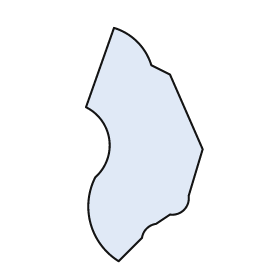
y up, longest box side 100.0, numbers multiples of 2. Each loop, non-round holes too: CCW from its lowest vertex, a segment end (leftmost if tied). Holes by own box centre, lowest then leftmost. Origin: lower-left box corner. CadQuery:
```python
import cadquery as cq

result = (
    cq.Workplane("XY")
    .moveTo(14.0, 0.0)
    .lineTo(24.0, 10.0)
    .threePointArc((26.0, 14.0), (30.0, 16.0))
    .lineTo(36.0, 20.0)
    .threePointArc((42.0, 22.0), (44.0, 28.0))
    .lineTo(50.0, 48.0)
    .lineTo(36.0, 80.0)
    .lineTo(28.0, 84.0)
    .threePointArc((22.0, 94.0), (12.0, 100.0))
    .lineTo(0.0, 66.0)
    .threePointArc((10.0, 52.0), (4.0, 36.0))
    .threePointArc((2.0, 16.0), (14.0, 0.0))
    .close()
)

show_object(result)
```